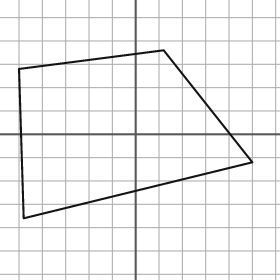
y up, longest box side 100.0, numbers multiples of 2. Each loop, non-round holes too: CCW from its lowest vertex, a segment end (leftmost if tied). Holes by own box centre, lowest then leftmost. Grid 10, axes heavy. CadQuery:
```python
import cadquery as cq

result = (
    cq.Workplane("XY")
    .moveTo(-48.0, -36.0)
    .lineTo(50.0, -12.0)
    .lineTo(12.0, 36.0)
    .lineTo(-50.0, 28.0)
    .close()
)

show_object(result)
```